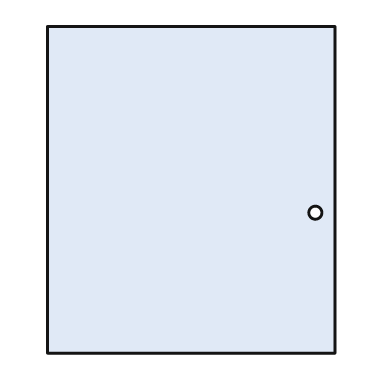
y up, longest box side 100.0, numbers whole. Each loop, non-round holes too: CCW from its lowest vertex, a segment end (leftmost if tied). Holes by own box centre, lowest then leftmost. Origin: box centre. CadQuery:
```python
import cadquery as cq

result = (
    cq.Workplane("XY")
    .moveTo(-44.0, -50.0)
    .lineTo(44.0, -50.0)
    .lineTo(44.0, 50.0)
    .lineTo(-44.0, 50.0)
    .close()
    .moveTo(38.0, -7.0)
    .circle(2.0)
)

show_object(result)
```